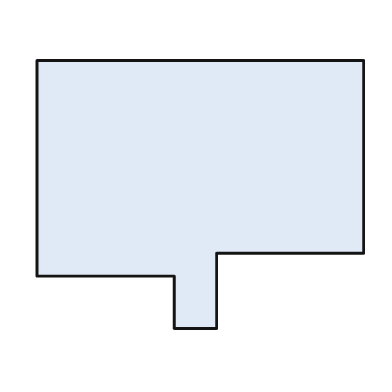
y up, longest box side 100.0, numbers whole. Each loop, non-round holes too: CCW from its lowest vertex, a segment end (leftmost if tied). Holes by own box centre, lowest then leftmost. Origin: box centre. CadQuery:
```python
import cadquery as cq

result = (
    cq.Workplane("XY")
    .moveTo(-8.0, -41.0)
    .lineTo(5.0, -41.0)
    .lineTo(5.0, -18.0)
    .lineTo(50.0, -18.0)
    .lineTo(50.0, 41.0)
    .lineTo(-50.0, 41.0)
    .lineTo(-50.0, -25.0)
    .lineTo(-8.0, -25.0)
    .close()
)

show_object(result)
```